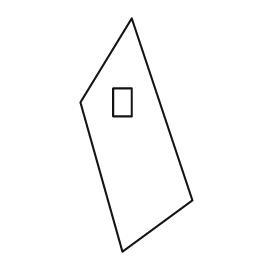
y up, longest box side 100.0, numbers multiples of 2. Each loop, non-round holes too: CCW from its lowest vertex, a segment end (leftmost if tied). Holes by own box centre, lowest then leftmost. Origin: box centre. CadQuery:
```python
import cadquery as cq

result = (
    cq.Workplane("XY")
    .moveTo(-6.0, -50.0)
    .lineTo(24.0, -28.0)
    .lineTo(-2.0, 50.0)
    .lineTo(-24.0, 14.0)
    .close()
    .moveTo(-10.0, 8.0)
    .lineTo(-2.0, 8.0)
    .lineTo(-2.0, 20.0)
    .lineTo(-10.0, 20.0)
    .close()
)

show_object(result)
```